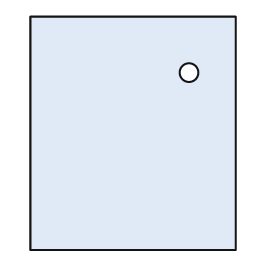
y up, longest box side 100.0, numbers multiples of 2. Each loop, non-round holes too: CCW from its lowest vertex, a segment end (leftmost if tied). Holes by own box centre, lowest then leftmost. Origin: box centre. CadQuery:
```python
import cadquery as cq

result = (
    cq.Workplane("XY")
    .moveTo(-44.0, -50.0)
    .lineTo(44.0, -50.0)
    .lineTo(44.0, 50.0)
    .lineTo(-44.0, 50.0)
    .close()
    .moveTo(24.0, 26.0)
    .circle(4.0)
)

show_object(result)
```